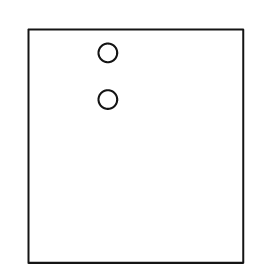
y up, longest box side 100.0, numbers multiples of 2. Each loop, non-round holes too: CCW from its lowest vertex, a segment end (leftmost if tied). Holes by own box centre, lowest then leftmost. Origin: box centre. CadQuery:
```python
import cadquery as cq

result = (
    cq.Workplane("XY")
    .moveTo(-46.0, -50.0)
    .lineTo(46.0, -50.0)
    .lineTo(46.0, 50.0)
    .lineTo(-46.0, 50.0)
    .close()
    .moveTo(-12.0, 20.0)
    .circle(4.0)
    .moveTo(-12.0, 40.0)
    .circle(4.0)
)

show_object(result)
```